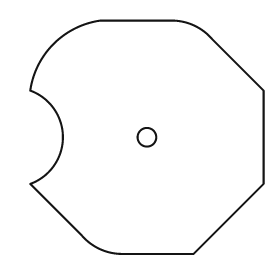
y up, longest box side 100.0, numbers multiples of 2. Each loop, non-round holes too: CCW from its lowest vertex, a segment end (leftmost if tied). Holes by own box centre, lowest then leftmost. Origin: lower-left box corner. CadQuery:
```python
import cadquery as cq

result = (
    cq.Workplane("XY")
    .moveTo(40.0, 0.0)
    .lineTo(70.0, 0.0)
    .lineTo(100.0, 30.0)
    .lineTo(100.0, 70.0)
    .lineTo(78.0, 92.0)
    .threePointArc((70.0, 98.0), (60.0, 100.0))
    .lineTo(30.0, 100.0)
    .threePointArc((10.0, 90.0), (0.0, 70.0))
    .threePointArc((14.0, 50.0), (0.0, 30.0))
    .lineTo(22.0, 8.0)
    .threePointArc((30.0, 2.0), (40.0, 0.0))
    .close()
    .moveTo(50.0, 50.0)
    .circle(4.0)
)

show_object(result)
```